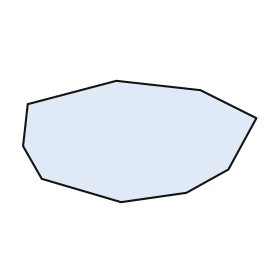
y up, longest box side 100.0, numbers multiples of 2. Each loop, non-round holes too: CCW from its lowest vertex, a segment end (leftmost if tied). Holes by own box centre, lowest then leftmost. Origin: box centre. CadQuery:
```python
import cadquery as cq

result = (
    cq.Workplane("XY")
    .moveTo(-8.0, -26.0)
    .lineTo(20.0, -22.0)
    .lineTo(38.0, -12.0)
    .lineTo(50.0, 10.0)
    .lineTo(26.0, 22.0)
    .lineTo(-10.0, 26.0)
    .lineTo(-48.0, 16.0)
    .lineTo(-50.0, -2.0)
    .lineTo(-42.0, -16.0)
    .close()
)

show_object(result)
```